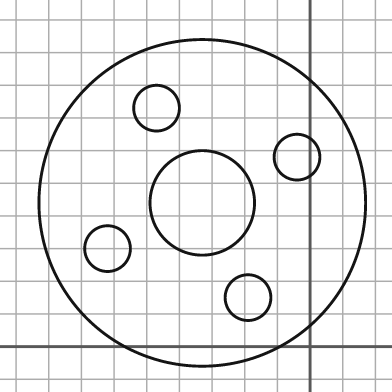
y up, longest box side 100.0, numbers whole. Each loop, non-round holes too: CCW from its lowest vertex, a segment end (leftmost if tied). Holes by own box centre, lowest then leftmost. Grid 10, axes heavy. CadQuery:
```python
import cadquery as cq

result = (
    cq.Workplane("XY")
    .moveTo(-33.0, 44.0)
    .circle(50.0)
    .moveTo(-19.0, 15.0)
    .circle(7.0)
    .moveTo(-62.0, 30.0)
    .circle(7.0)
    .moveTo(-33.0, 44.0)
    .circle(16.0)
    .moveTo(-4.0, 58.0)
    .circle(7.0)
    .moveTo(-47.0, 73.0)
    .circle(7.0)
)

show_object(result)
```